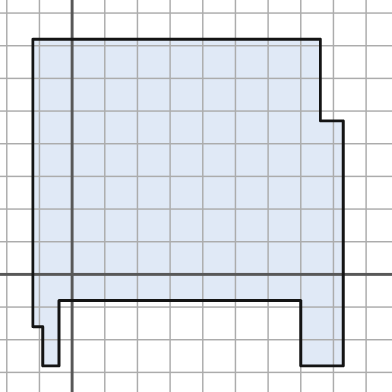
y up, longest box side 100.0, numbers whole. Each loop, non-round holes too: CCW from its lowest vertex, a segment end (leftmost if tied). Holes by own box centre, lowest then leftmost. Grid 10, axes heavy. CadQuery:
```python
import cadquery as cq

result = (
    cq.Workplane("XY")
    .moveTo(-9.0, -28.0)
    .lineTo(-4.0, -28.0)
    .lineTo(-4.0, -8.0)
    .lineTo(70.0, -8.0)
    .lineTo(70.0, -28.0)
    .lineTo(83.0, -28.0)
    .lineTo(83.0, 47.0)
    .lineTo(76.0, 47.0)
    .lineTo(76.0, 72.0)
    .lineTo(-12.0, 72.0)
    .lineTo(-12.0, -16.0)
    .lineTo(-9.0, -16.0)
    .close()
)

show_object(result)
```